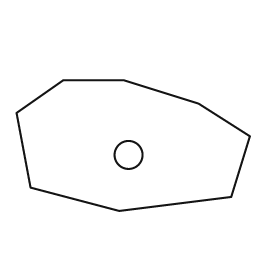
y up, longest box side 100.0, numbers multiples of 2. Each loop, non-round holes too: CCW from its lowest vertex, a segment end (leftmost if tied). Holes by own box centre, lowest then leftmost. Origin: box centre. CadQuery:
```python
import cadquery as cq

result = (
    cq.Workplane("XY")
    .moveTo(-6.0, -28.0)
    .lineTo(42.0, -22.0)
    .lineTo(50.0, 4.0)
    .lineTo(28.0, 18.0)
    .lineTo(-4.0, 28.0)
    .lineTo(-30.0, 28.0)
    .lineTo(-50.0, 14.0)
    .lineTo(-44.0, -18.0)
    .close()
    .moveTo(-2.0, -4.0)
    .circle(6.0)
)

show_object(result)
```